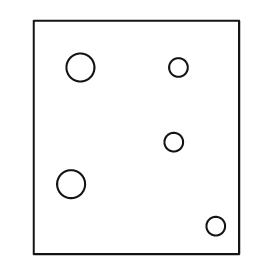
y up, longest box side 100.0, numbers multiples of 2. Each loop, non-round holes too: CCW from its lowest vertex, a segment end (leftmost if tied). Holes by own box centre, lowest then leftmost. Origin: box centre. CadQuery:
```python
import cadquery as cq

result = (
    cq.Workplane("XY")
    .moveTo(-44.0, -50.0)
    .lineTo(44.0, -50.0)
    .lineTo(44.0, 50.0)
    .lineTo(-44.0, 50.0)
    .close()
    .moveTo(34.0, -38.0)
    .circle(4.0)
    .moveTo(-28.0, -20.0)
    .circle(6.0)
    .moveTo(16.0, -2.0)
    .circle(4.0)
    .moveTo(-24.0, 30.0)
    .circle(6.0)
    .moveTo(18.0, 30.0)
    .circle(4.0)
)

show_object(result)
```